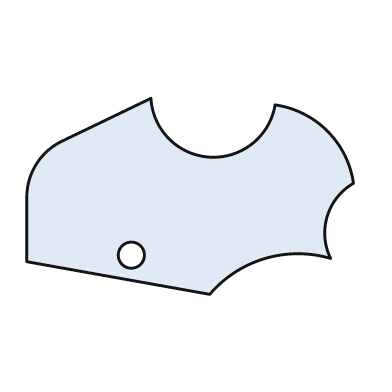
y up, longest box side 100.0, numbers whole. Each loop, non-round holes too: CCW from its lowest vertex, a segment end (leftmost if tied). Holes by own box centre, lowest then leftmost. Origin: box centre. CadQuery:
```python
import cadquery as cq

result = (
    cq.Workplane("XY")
    .moveTo(6.0, -30.0)
    .threePointArc((23.0, -19.0), (43.0, -19.0))
    .threePointArc((42.0, -6.0), (50.0, 4.0))
    .threePointArc((42.0, 20.0), (26.0, 28.0))
    .threePointArc((6.0, 12.0), (-12.0, 30.0))
    .lineTo(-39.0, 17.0)
    .threePointArc((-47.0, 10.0), (-50.0, 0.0))
    .lineTo(-50.0, -20.0)
    .close()
    .moveTo(-18.0, -18.0)
    .circle(4.0)
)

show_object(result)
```